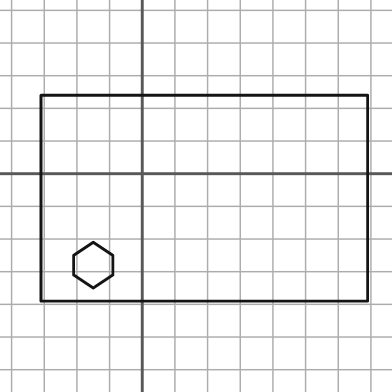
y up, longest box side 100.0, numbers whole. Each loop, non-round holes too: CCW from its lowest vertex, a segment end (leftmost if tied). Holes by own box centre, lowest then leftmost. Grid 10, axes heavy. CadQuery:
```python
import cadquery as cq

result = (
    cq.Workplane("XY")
    .moveTo(-31.0, -39.0)
    .lineTo(69.0, -39.0)
    .lineTo(69.0, 24.0)
    .lineTo(-31.0, 24.0)
    .close()
    .moveTo(-15.0, -35.0)
    .lineTo(-9.0, -31.0)
    .lineTo(-9.0, -25.0)
    .lineTo(-15.0, -21.0)
    .lineTo(-21.0, -25.0)
    .lineTo(-21.0, -31.0)
    .close()
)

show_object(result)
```